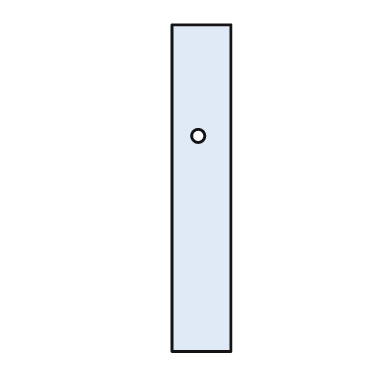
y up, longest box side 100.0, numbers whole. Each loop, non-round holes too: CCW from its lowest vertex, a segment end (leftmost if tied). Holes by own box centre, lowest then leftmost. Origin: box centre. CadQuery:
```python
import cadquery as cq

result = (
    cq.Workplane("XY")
    .moveTo(-9.0, -50.0)
    .lineTo(9.0, -50.0)
    .lineTo(9.0, 50.0)
    .lineTo(-9.0, 50.0)
    .close()
    .moveTo(-1.0, 16.0)
    .circle(2.0)
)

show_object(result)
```